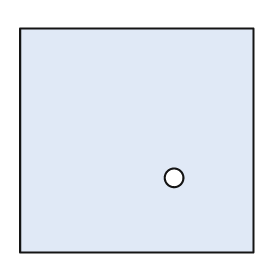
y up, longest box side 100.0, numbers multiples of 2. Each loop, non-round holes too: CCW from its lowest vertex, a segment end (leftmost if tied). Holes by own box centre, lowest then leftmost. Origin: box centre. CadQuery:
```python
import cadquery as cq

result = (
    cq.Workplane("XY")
    .moveTo(-50.0, -48.0)
    .lineTo(50.0, -48.0)
    .lineTo(50.0, 48.0)
    .lineTo(-50.0, 48.0)
    .close()
    .moveTo(16.0, -16.0)
    .circle(4.0)
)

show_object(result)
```